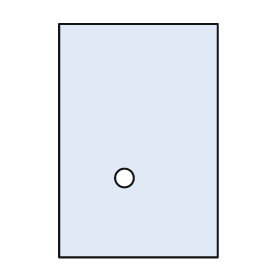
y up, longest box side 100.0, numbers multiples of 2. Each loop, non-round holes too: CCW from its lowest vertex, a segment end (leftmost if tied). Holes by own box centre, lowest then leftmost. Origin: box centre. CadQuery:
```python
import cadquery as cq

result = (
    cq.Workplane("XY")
    .moveTo(-34.0, -50.0)
    .lineTo(34.0, -50.0)
    .lineTo(34.0, 50.0)
    .lineTo(-34.0, 50.0)
    .close()
    .moveTo(-6.0, -16.0)
    .circle(4.0)
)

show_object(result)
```